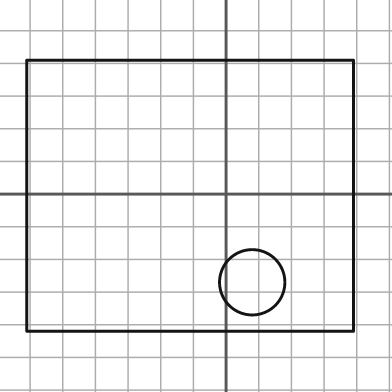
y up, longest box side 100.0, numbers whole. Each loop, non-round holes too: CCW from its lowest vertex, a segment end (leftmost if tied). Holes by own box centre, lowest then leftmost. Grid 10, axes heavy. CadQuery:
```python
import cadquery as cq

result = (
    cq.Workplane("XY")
    .moveTo(-61.0, -42.0)
    .lineTo(39.0, -42.0)
    .lineTo(39.0, 41.0)
    .lineTo(-61.0, 41.0)
    .close()
    .moveTo(8.0, -27.0)
    .circle(10.0)
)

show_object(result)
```